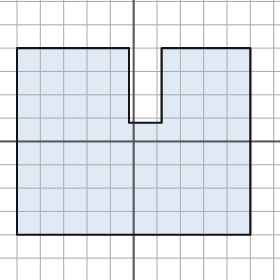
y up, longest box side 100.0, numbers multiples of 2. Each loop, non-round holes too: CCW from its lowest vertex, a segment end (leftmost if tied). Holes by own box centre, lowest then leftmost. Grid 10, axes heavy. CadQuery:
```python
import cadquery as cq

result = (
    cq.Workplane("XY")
    .moveTo(-50.0, -40.0)
    .lineTo(50.0, -40.0)
    .lineTo(50.0, 40.0)
    .lineTo(12.0, 40.0)
    .lineTo(12.0, 8.0)
    .lineTo(-2.0, 8.0)
    .lineTo(-2.0, 40.0)
    .lineTo(-50.0, 40.0)
    .close()
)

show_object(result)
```